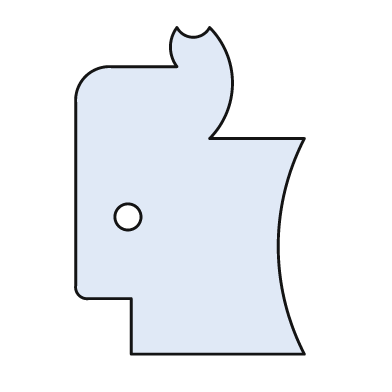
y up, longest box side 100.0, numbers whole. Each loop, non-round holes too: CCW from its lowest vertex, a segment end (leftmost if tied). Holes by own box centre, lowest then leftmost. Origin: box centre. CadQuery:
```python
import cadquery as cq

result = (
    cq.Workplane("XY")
    .moveTo(-18.0, -50.0)
    .lineTo(35.0, -50.0)
    .threePointArc((27.0, -17.0), (35.0, 16.0))
    .lineTo(6.0, 16.0)
    .threePointArc((13.0, 33.0), (6.0, 50.0))
    .threePointArc((1.0, 47.0), (-4.0, 50.0))
    .threePointArc((-6.0, 44.0), (-4.0, 38.0))
    .lineTo(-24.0, 38.0)
    .threePointArc((-32.0, 35.0), (-35.0, 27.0))
    .lineTo(-35.0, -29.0)
    .threePointArc((-34.0, -32.0), (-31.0, -33.0))
    .lineTo(-18.0, -33.0)
    .close()
    .moveTo(-19.0, -8.0)
    .circle(4.0)
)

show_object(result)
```